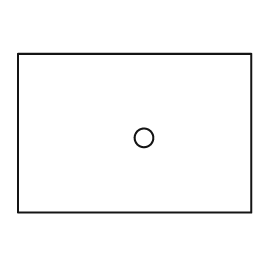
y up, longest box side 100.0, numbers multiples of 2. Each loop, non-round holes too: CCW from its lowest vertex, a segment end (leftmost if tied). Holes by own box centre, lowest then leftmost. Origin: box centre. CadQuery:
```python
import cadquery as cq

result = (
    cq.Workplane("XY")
    .moveTo(-50.0, -34.0)
    .lineTo(50.0, -34.0)
    .lineTo(50.0, 34.0)
    .lineTo(-50.0, 34.0)
    .close()
    .moveTo(4.0, -2.0)
    .circle(4.0)
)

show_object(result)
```